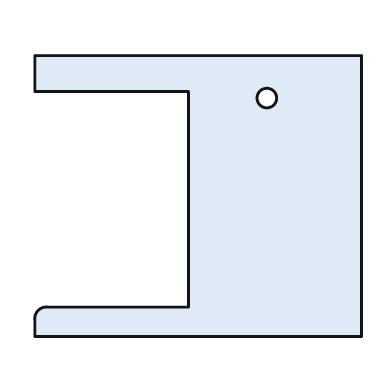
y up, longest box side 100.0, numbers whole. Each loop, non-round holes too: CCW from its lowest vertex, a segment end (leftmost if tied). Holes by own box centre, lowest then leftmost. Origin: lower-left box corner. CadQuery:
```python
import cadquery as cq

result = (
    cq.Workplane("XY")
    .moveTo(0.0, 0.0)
    .lineTo(100.0, 0.0)
    .lineTo(100.0, 86.0)
    .lineTo(0.0, 86.0)
    .lineTo(0.0, 75.0)
    .lineTo(47.0, 75.0)
    .lineTo(47.0, 9.0)
    .lineTo(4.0, 9.0)
    .threePointArc((1.0, 8.0), (0.0, 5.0))
    .close()
    .moveTo(71.0, 73.0)
    .circle(3.0)
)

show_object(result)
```